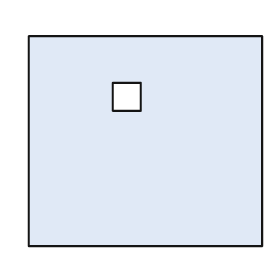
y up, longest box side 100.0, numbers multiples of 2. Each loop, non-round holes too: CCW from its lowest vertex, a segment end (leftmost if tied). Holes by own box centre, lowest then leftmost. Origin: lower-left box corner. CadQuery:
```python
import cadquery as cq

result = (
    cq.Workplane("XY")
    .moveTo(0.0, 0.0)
    .lineTo(100.0, 0.0)
    .lineTo(100.0, 90.0)
    .lineTo(0.0, 90.0)
    .close()
    .moveTo(36.0, 58.0)
    .lineTo(48.0, 58.0)
    .lineTo(48.0, 70.0)
    .lineTo(36.0, 70.0)
    .close()
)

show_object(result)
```